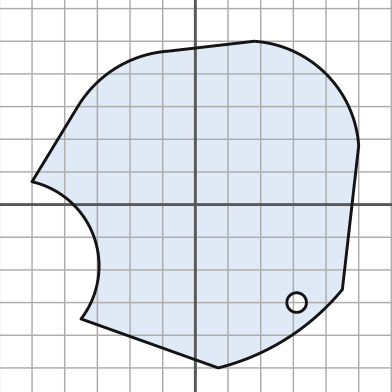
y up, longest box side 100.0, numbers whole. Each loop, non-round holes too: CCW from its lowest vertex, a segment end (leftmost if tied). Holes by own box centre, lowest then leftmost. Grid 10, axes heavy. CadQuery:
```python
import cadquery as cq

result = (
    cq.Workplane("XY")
    .moveTo(7.0, -50.0)
    .threePointArc((28.0, -41.0), (45.0, -26.0))
    .lineTo(50.0, 18.0)
    .threePointArc((40.0, 40.0), (18.0, 50.0))
    .lineTo(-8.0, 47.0)
    .threePointArc((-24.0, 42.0), (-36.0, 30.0))
    .lineTo(-50.0, 7.0)
    .threePointArc((-31.0, -10.0), (-35.0, -35.0))
    .close()
    .moveTo(31.0, -30.0)
    .circle(3.0)
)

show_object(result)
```